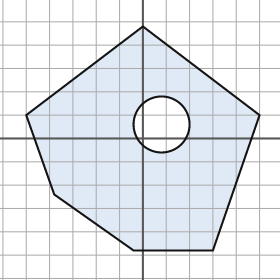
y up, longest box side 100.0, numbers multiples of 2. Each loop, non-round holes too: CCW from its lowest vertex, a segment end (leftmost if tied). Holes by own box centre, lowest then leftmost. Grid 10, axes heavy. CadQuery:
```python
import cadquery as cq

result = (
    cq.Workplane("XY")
    .moveTo(-4.0, -48.0)
    .lineTo(30.0, -48.0)
    .lineTo(50.0, 10.0)
    .lineTo(0.0, 48.0)
    .lineTo(-50.0, 10.0)
    .lineTo(-38.0, -24.0)
    .close()
    .moveTo(8.0, 6.0)
    .circle(12.0)
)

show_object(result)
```